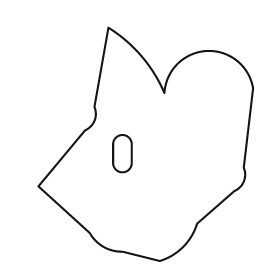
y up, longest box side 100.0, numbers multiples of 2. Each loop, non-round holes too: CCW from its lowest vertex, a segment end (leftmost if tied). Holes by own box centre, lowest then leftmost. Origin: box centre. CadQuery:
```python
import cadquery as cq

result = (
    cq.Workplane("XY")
    .moveTo(6.0, -50.0)
    .threePointArc((16.0, -44.0), (22.0, -34.0))
    .lineTo(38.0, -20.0)
    .threePointArc((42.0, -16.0), (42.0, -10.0))
    .lineTo(46.0, 24.0)
    .threePointArc((26.0, 40.0), (8.0, 22.0))
    .threePointArc((-2.0, 38.0), (-16.0, 50.0))
    .lineTo(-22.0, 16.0)
    .threePointArc((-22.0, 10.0), (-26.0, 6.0))
    .lineTo(-46.0, -18.0)
    .lineTo(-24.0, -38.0)
    .threePointArc((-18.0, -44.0), (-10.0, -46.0))
    .close()
    .moveTo(-14.0, -8.0)
    .threePointArc((-10.0, -12.0), (-6.0, -8.0))
    .lineTo(-6.0, 0.0)
    .threePointArc((-10.0, 4.0), (-14.0, 0.0))
    .close()
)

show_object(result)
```